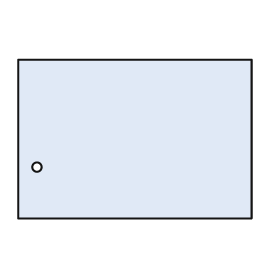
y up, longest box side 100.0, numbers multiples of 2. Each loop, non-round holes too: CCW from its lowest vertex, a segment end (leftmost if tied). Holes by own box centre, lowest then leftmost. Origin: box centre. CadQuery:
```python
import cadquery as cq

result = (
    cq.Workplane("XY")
    .moveTo(-50.0, -34.0)
    .lineTo(50.0, -34.0)
    .lineTo(50.0, 34.0)
    .lineTo(-50.0, 34.0)
    .close()
    .moveTo(-42.0, -12.0)
    .circle(2.0)
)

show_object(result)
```